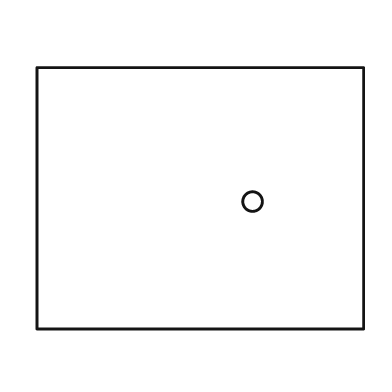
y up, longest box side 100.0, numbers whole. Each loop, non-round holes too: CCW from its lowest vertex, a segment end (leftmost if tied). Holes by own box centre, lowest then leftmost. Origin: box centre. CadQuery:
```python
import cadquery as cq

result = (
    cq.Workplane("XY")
    .moveTo(-50.0, -40.0)
    .lineTo(50.0, -40.0)
    .lineTo(50.0, 40.0)
    .lineTo(-50.0, 40.0)
    .close()
    .moveTo(16.0, -1.0)
    .circle(3.0)
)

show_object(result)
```